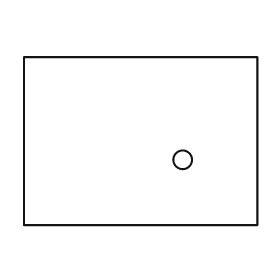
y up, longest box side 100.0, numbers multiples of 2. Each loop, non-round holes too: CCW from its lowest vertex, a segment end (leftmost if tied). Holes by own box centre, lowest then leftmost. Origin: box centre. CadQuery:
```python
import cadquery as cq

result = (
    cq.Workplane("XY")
    .moveTo(-50.0, -36.0)
    .lineTo(50.0, -36.0)
    .lineTo(50.0, 36.0)
    .lineTo(-50.0, 36.0)
    .close()
    .moveTo(18.0, -8.0)
    .circle(4.0)
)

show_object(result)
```